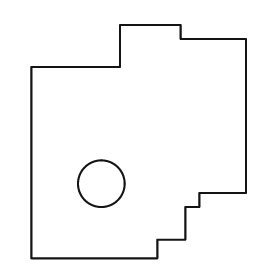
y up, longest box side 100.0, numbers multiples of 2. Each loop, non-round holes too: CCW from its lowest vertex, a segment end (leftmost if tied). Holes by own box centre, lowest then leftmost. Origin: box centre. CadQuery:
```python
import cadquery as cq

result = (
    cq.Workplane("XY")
    .moveTo(-46.0, -50.0)
    .lineTo(8.0, -50.0)
    .lineTo(8.0, -42.0)
    .lineTo(20.0, -42.0)
    .lineTo(20.0, -28.0)
    .lineTo(26.0, -28.0)
    .lineTo(26.0, -22.0)
    .lineTo(46.0, -22.0)
    .lineTo(46.0, 44.0)
    .lineTo(18.0, 44.0)
    .lineTo(18.0, 50.0)
    .lineTo(-8.0, 50.0)
    .lineTo(-8.0, 32.0)
    .lineTo(-46.0, 32.0)
    .close()
    .moveTo(-16.0, -18.0)
    .circle(10.0)
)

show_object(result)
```